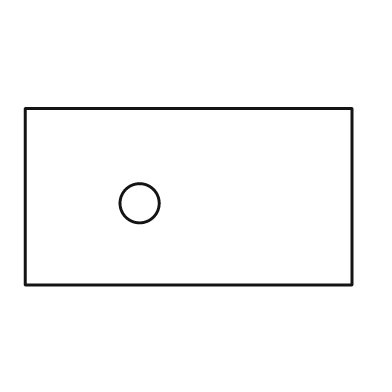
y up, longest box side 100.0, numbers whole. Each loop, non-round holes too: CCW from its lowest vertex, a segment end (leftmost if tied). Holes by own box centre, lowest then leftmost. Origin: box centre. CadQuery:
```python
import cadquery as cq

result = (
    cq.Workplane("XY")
    .moveTo(-50.0, -27.0)
    .lineTo(50.0, -27.0)
    .lineTo(50.0, 27.0)
    .lineTo(-50.0, 27.0)
    .close()
    .moveTo(-15.0, -2.0)
    .circle(6.0)
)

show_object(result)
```